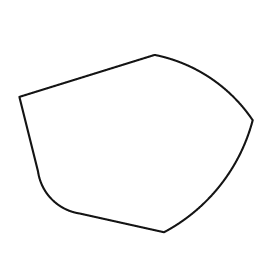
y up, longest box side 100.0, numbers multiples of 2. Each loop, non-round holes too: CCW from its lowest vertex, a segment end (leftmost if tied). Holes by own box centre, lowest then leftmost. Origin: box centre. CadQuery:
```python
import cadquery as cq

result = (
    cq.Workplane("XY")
    .moveTo(12.0, -38.0)
    .threePointArc((36.0, -18.0), (50.0, 10.0))
    .threePointArc((32.0, 28.0), (8.0, 38.0))
    .lineTo(-50.0, 20.0)
    .lineTo(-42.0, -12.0)
    .threePointArc((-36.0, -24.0), (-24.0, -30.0))
    .close()
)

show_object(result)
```